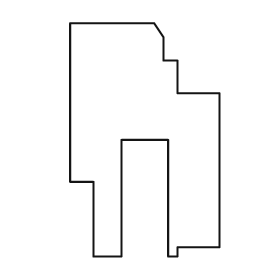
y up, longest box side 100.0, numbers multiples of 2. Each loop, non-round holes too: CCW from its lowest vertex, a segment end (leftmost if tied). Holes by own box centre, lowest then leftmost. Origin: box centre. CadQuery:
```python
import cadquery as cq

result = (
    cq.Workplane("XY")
    .moveTo(-22.0, -50.0)
    .lineTo(-10.0, -50.0)
    .lineTo(-10.0, 0.0)
    .lineTo(10.0, 0.0)
    .lineTo(10.0, -50.0)
    .lineTo(14.0, -50.0)
    .lineTo(14.0, -46.0)
    .lineTo(32.0, -46.0)
    .lineTo(32.0, 20.0)
    .lineTo(14.0, 20.0)
    .lineTo(14.0, 34.0)
    .lineTo(8.0, 34.0)
    .lineTo(8.0, 44.0)
    .lineTo(4.0, 50.0)
    .lineTo(-32.0, 50.0)
    .lineTo(-32.0, -18.0)
    .lineTo(-22.0, -18.0)
    .close()
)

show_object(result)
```